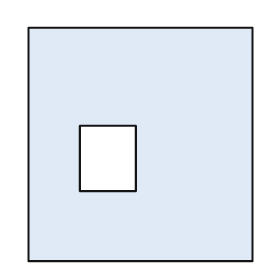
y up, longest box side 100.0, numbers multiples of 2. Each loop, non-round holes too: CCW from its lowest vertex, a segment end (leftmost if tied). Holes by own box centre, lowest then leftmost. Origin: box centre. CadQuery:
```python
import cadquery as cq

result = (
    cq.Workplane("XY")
    .moveTo(-48.0, -50.0)
    .lineTo(48.0, -50.0)
    .lineTo(48.0, 50.0)
    .lineTo(-48.0, 50.0)
    .close()
    .moveTo(-26.0, -20.0)
    .lineTo(-2.0, -20.0)
    .lineTo(-2.0, 8.0)
    .lineTo(-26.0, 8.0)
    .close()
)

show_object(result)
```